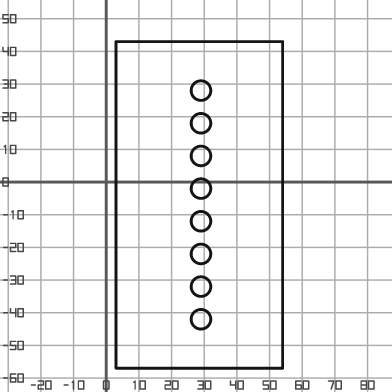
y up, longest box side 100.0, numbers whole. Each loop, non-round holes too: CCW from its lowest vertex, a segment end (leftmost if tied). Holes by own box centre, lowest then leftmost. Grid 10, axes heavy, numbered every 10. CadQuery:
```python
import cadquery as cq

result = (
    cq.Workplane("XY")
    .moveTo(3.0, -57.0)
    .lineTo(54.0, -57.0)
    .lineTo(54.0, 43.0)
    .lineTo(3.0, 43.0)
    .close()
    .moveTo(29.0, -42.0)
    .circle(3.0)
    .moveTo(29.0, -32.0)
    .circle(3.0)
    .moveTo(29.0, -22.0)
    .circle(3.0)
    .moveTo(29.0, -12.0)
    .circle(3.0)
    .moveTo(29.0, -2.0)
    .circle(3.0)
    .moveTo(29.0, 8.0)
    .circle(3.0)
    .moveTo(29.0, 18.0)
    .circle(3.0)
    .moveTo(29.0, 28.0)
    .circle(3.0)
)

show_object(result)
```